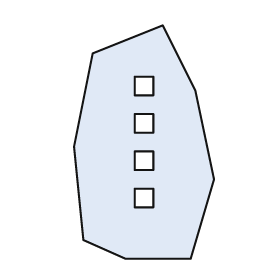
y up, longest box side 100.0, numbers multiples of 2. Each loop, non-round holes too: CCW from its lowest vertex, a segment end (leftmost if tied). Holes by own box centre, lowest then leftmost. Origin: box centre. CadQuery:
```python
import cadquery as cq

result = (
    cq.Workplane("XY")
    .moveTo(-8.0, -50.0)
    .lineTo(20.0, -50.0)
    .lineTo(30.0, -16.0)
    .lineTo(22.0, 22.0)
    .lineTo(8.0, 50.0)
    .lineTo(-22.0, 38.0)
    .lineTo(-30.0, -2.0)
    .lineTo(-26.0, -42.0)
    .close()
    .moveTo(-4.0, -28.0)
    .lineTo(4.0, -28.0)
    .lineTo(4.0, -20.0)
    .lineTo(-4.0, -20.0)
    .close()
    .moveTo(-4.0, -12.0)
    .lineTo(4.0, -12.0)
    .lineTo(4.0, -4.0)
    .lineTo(-4.0, -4.0)
    .close()
    .moveTo(-4.0, 4.0)
    .lineTo(4.0, 4.0)
    .lineTo(4.0, 12.0)
    .lineTo(-4.0, 12.0)
    .close()
    .moveTo(-4.0, 20.0)
    .lineTo(4.0, 20.0)
    .lineTo(4.0, 28.0)
    .lineTo(-4.0, 28.0)
    .close()
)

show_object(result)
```